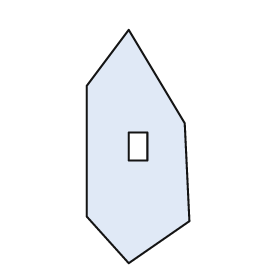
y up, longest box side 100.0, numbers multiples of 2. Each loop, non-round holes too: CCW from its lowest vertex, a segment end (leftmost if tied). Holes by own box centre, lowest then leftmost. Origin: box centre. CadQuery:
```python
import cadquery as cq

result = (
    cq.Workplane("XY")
    .moveTo(-4.0, -50.0)
    .lineTo(22.0, -32.0)
    .lineTo(20.0, 10.0)
    .lineTo(-4.0, 50.0)
    .lineTo(-22.0, 26.0)
    .lineTo(-22.0, -30.0)
    .close()
    .moveTo(-4.0, -6.0)
    .lineTo(4.0, -6.0)
    .lineTo(4.0, 6.0)
    .lineTo(-4.0, 6.0)
    .close()
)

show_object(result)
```